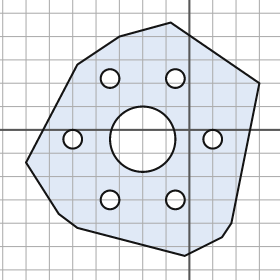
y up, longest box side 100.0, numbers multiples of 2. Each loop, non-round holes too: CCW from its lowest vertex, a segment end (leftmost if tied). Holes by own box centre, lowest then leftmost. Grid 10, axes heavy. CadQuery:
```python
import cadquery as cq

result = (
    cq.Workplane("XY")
    .moveTo(-2.0, -54.0)
    .lineTo(14.0, -46.0)
    .lineTo(18.0, -40.0)
    .lineTo(30.0, 20.0)
    .lineTo(-8.0, 46.0)
    .lineTo(-30.0, 40.0)
    .lineTo(-48.0, 28.0)
    .lineTo(-70.0, -14.0)
    .lineTo(-56.0, -36.0)
    .lineTo(-48.0, -42.0)
    .close()
    .moveTo(-34.0, -30.0)
    .circle(4.0)
    .moveTo(-6.0, -30.0)
    .circle(4.0)
    .moveTo(-50.0, -4.0)
    .circle(4.0)
    .moveTo(-20.0, -4.0)
    .circle(14.0)
    .moveTo(10.0, -4.0)
    .circle(4.0)
    .moveTo(-34.0, 22.0)
    .circle(4.0)
    .moveTo(-6.0, 22.0)
    .circle(4.0)
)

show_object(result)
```